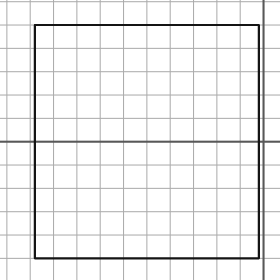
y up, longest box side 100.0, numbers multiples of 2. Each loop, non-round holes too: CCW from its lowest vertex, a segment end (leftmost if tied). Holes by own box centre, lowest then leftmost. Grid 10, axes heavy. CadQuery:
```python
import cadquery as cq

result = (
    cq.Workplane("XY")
    .moveTo(-98.0, -50.0)
    .lineTo(-2.0, -50.0)
    .lineTo(-2.0, 50.0)
    .lineTo(-98.0, 50.0)
    .close()
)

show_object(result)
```